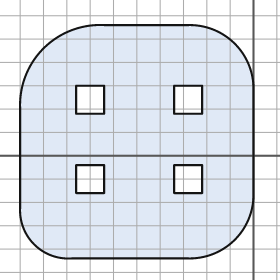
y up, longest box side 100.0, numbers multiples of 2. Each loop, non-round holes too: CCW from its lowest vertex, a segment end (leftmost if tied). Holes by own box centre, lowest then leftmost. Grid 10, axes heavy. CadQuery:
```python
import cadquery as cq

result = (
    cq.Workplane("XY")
    .moveTo(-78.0, -44.0)
    .lineTo(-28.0, -44.0)
    .threePointArc((-8.0, -36.0), (0.0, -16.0))
    .lineTo(0.0, 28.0)
    .threePointArc((-8.0, 48.0), (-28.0, 56.0))
    .lineTo(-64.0, 56.0)
    .threePointArc((-90.0, 46.0), (-100.0, 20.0))
    .lineTo(-100.0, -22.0)
    .threePointArc((-94.0, -38.0), (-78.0, -44.0))
    .close()
    .moveTo(-76.0, -16.0)
    .lineTo(-64.0, -16.0)
    .lineTo(-64.0, -4.0)
    .lineTo(-76.0, -4.0)
    .close()
    .moveTo(-34.0, -16.0)
    .lineTo(-22.0, -16.0)
    .lineTo(-22.0, -4.0)
    .lineTo(-34.0, -4.0)
    .close()
    .moveTo(-76.0, 18.0)
    .lineTo(-64.0, 18.0)
    .lineTo(-64.0, 30.0)
    .lineTo(-76.0, 30.0)
    .close()
    .moveTo(-34.0, 18.0)
    .lineTo(-22.0, 18.0)
    .lineTo(-22.0, 30.0)
    .lineTo(-34.0, 30.0)
    .close()
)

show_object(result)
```